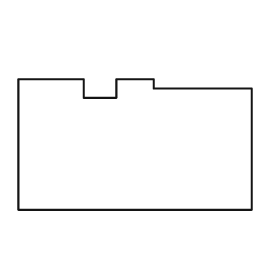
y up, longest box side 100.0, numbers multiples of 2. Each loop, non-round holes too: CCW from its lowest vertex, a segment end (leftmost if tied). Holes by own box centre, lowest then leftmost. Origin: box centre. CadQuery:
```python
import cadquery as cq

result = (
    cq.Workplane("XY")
    .moveTo(-50.0, -28.0)
    .lineTo(50.0, -28.0)
    .lineTo(50.0, 24.0)
    .lineTo(8.0, 24.0)
    .lineTo(8.0, 28.0)
    .lineTo(-8.0, 28.0)
    .lineTo(-8.0, 20.0)
    .lineTo(-22.0, 20.0)
    .lineTo(-22.0, 28.0)
    .lineTo(-50.0, 28.0)
    .close()
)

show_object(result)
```